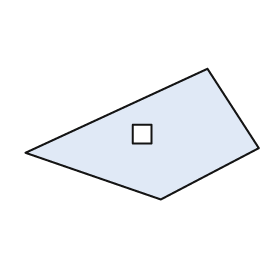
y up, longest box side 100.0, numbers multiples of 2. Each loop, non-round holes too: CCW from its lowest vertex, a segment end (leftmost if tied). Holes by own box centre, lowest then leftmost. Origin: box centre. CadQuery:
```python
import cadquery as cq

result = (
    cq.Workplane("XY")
    .moveTo(8.0, -28.0)
    .lineTo(50.0, -6.0)
    .lineTo(28.0, 28.0)
    .lineTo(-50.0, -8.0)
    .close()
    .moveTo(-4.0, -4.0)
    .lineTo(4.0, -4.0)
    .lineTo(4.0, 4.0)
    .lineTo(-4.0, 4.0)
    .close()
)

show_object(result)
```